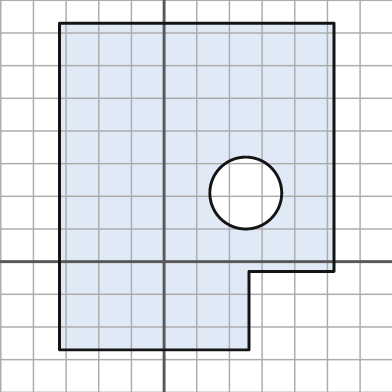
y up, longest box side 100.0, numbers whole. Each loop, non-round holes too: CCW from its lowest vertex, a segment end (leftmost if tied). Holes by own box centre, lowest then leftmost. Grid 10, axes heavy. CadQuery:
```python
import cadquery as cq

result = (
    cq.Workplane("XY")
    .moveTo(-32.0, -27.0)
    .lineTo(26.0, -27.0)
    .lineTo(26.0, -3.0)
    .lineTo(52.0, -3.0)
    .lineTo(52.0, 73.0)
    .lineTo(-32.0, 73.0)
    .close()
    .moveTo(25.0, 21.0)
    .circle(11.0)
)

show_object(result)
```